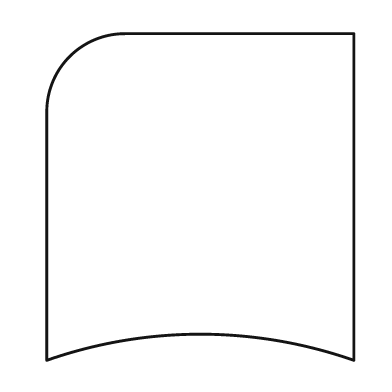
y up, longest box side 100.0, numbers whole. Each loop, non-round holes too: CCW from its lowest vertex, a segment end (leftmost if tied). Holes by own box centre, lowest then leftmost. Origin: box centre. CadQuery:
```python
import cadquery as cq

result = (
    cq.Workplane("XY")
    .moveTo(-47.0, -50.0)
    .threePointArc((0.0, -42.0), (47.0, -50.0))
    .lineTo(47.0, 50.0)
    .lineTo(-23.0, 50.0)
    .threePointArc((-40.0, 43.0), (-47.0, 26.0))
    .close()
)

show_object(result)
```